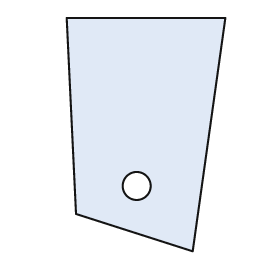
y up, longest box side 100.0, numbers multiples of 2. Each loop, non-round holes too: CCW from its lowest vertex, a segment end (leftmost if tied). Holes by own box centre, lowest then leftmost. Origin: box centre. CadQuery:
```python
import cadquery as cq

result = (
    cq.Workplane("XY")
    .moveTo(20.0, -50.0)
    .lineTo(34.0, 50.0)
    .lineTo(-34.0, 50.0)
    .lineTo(-30.0, -34.0)
    .close()
    .moveTo(-4.0, -22.0)
    .circle(6.0)
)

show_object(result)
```